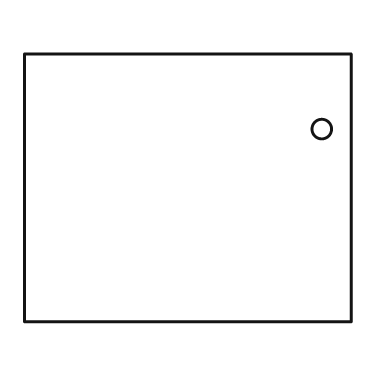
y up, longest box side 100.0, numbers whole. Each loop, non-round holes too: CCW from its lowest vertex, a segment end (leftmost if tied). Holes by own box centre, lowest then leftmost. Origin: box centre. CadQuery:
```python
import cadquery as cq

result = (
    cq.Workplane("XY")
    .moveTo(-50.0, -41.0)
    .lineTo(50.0, -41.0)
    .lineTo(50.0, 41.0)
    .lineTo(-50.0, 41.0)
    .close()
    .moveTo(41.0, 18.0)
    .circle(3.0)
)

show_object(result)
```